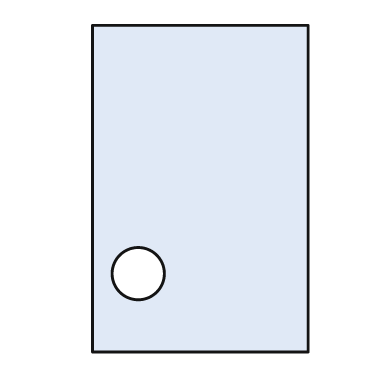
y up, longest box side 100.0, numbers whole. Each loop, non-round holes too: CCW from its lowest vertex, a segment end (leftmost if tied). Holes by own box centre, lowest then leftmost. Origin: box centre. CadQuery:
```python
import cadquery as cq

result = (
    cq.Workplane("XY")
    .moveTo(-33.0, -50.0)
    .lineTo(33.0, -50.0)
    .lineTo(33.0, 50.0)
    .lineTo(-33.0, 50.0)
    .close()
    .moveTo(-19.0, -26.0)
    .circle(8.0)
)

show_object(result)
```